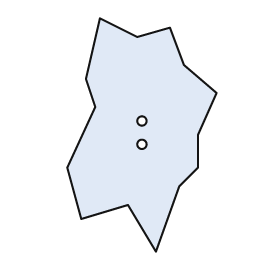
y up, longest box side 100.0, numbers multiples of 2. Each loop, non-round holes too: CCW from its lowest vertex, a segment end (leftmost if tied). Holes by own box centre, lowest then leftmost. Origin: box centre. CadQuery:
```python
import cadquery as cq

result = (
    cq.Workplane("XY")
    .moveTo(6.0, -50.0)
    .lineTo(16.0, -22.0)
    .lineTo(24.0, -14.0)
    .lineTo(24.0, 0.0)
    .lineTo(32.0, 18.0)
    .lineTo(18.0, 30.0)
    .lineTo(12.0, 46.0)
    .lineTo(-2.0, 42.0)
    .lineTo(-18.0, 50.0)
    .lineTo(-24.0, 24.0)
    .lineTo(-20.0, 12.0)
    .lineTo(-32.0, -14.0)
    .lineTo(-26.0, -36.0)
    .lineTo(-6.0, -30.0)
    .close()
    .moveTo(0.0, -4.0)
    .circle(2.0)
    .moveTo(0.0, 6.0)
    .circle(2.0)
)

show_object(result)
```